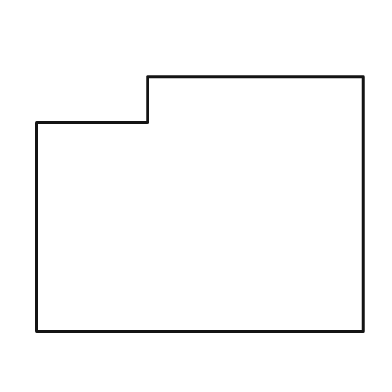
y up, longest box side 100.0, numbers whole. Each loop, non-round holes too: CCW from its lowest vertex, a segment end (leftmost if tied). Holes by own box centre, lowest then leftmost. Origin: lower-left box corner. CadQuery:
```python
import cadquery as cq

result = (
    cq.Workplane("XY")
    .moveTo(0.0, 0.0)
    .lineTo(100.0, 0.0)
    .lineTo(100.0, 78.0)
    .lineTo(34.0, 78.0)
    .lineTo(34.0, 64.0)
    .lineTo(0.0, 64.0)
    .close()
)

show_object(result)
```